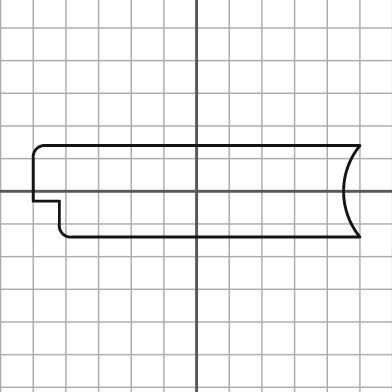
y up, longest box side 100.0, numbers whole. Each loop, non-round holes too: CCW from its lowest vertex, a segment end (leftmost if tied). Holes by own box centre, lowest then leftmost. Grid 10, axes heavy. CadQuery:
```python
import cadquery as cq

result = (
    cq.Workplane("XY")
    .moveTo(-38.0, -14.0)
    .lineTo(50.0, -14.0)
    .threePointArc((45.0, 0.0), (50.0, 14.0))
    .lineTo(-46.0, 14.0)
    .threePointArc((-49.0, 13.0), (-50.0, 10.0))
    .lineTo(-50.0, -3.0)
    .lineTo(-42.0, -3.0)
    .lineTo(-42.0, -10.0)
    .threePointArc((-41.0, -13.0), (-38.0, -14.0))
    .close()
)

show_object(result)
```